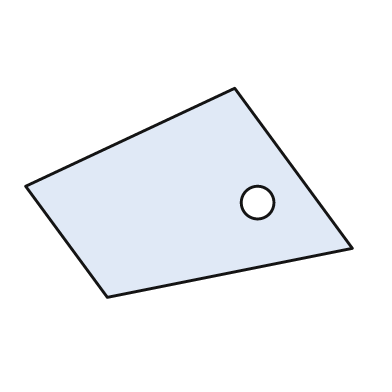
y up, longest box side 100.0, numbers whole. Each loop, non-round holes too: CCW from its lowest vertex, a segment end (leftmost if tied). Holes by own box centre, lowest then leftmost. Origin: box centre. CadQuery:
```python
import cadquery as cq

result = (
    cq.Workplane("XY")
    .moveTo(-25.0, -32.0)
    .lineTo(50.0, -17.0)
    .lineTo(14.0, 32.0)
    .lineTo(-50.0, 2.0)
    .close()
    .moveTo(21.0, -3.0)
    .circle(5.0)
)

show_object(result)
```